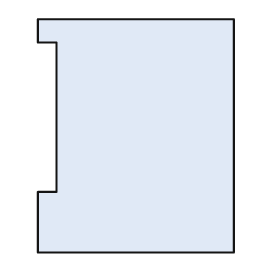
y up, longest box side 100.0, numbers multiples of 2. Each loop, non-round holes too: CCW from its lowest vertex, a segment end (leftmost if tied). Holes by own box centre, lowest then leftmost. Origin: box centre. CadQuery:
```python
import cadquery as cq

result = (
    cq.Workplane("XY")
    .moveTo(-42.0, -50.0)
    .lineTo(42.0, -50.0)
    .lineTo(42.0, 50.0)
    .lineTo(-42.0, 50.0)
    .lineTo(-42.0, 40.0)
    .lineTo(-34.0, 40.0)
    .lineTo(-34.0, -24.0)
    .lineTo(-42.0, -24.0)
    .close()
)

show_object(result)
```